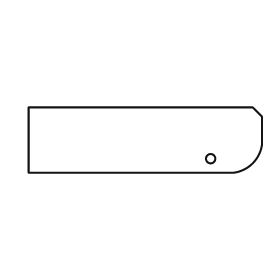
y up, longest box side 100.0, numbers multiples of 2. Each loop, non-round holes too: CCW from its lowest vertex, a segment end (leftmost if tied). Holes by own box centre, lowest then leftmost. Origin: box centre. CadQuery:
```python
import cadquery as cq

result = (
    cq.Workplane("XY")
    .moveTo(-50.0, -14.0)
    .lineTo(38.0, -14.0)
    .threePointArc((46.0, -10.0), (50.0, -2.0))
    .lineTo(50.0, 10.0)
    .lineTo(46.0, 14.0)
    .lineTo(-50.0, 14.0)
    .close()
    .moveTo(28.0, -8.0)
    .circle(2.0)
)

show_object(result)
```